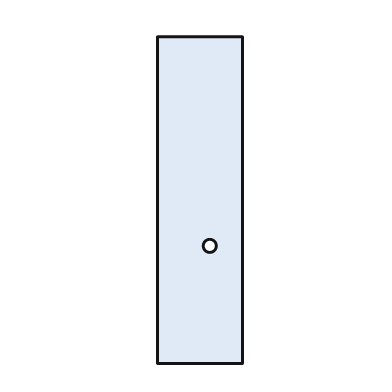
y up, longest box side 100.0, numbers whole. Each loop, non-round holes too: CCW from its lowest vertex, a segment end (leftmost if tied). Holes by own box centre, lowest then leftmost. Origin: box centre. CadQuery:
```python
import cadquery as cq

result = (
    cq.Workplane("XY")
    .moveTo(-13.0, -50.0)
    .lineTo(13.0, -50.0)
    .lineTo(13.0, 50.0)
    .lineTo(-13.0, 50.0)
    .close()
    .moveTo(3.0, -14.0)
    .circle(2.0)
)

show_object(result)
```